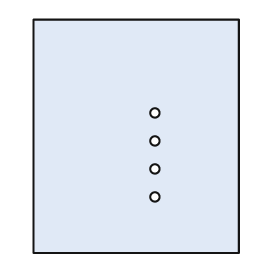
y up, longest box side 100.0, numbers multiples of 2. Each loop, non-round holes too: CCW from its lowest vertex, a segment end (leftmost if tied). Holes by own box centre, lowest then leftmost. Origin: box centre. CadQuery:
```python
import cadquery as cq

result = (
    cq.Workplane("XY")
    .moveTo(-44.0, -50.0)
    .lineTo(44.0, -50.0)
    .lineTo(44.0, 50.0)
    .lineTo(-44.0, 50.0)
    .close()
    .moveTo(8.0, -26.0)
    .circle(2.0)
    .moveTo(8.0, -14.0)
    .circle(2.0)
    .moveTo(8.0, -2.0)
    .circle(2.0)
    .moveTo(8.0, 10.0)
    .circle(2.0)
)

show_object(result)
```